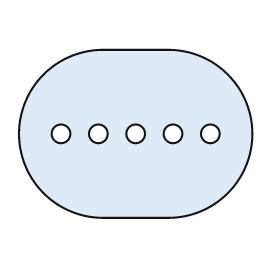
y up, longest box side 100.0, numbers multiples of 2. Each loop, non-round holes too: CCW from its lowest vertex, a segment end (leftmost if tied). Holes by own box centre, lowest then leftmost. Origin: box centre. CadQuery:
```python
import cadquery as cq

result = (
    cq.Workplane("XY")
    .moveTo(-14.0, -36.0)
    .lineTo(14.0, -36.0)
    .threePointArc((50.0, 0.0), (14.0, 36.0))
    .lineTo(-14.0, 36.0)
    .threePointArc((-50.0, 0.0), (-14.0, -36.0))
    .close()
    .moveTo(-32.0, 0.0)
    .circle(4.0)
    .moveTo(-16.0, 0.0)
    .circle(4.0)
    .moveTo(0.0, 0.0)
    .circle(4.0)
    .moveTo(16.0, 0.0)
    .circle(4.0)
    .moveTo(32.0, 0.0)
    .circle(4.0)
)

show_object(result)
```